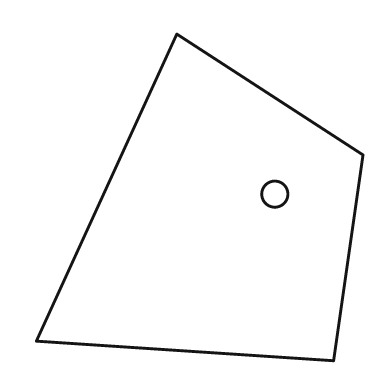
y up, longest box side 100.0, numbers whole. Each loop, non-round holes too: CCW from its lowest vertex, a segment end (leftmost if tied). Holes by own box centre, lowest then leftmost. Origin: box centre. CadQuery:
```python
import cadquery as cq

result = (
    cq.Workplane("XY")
    .moveTo(41.0, -50.0)
    .lineTo(50.0, 13.0)
    .lineTo(-7.0, 50.0)
    .lineTo(-50.0, -44.0)
    .close()
    .moveTo(23.0, 1.0)
    .circle(4.0)
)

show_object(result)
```